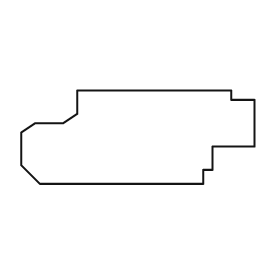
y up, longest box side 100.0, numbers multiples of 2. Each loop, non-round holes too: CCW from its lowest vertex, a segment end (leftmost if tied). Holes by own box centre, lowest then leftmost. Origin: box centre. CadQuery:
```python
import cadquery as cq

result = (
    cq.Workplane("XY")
    .moveTo(-42.0, -20.0)
    .lineTo(28.0, -20.0)
    .lineTo(28.0, -14.0)
    .lineTo(32.0, -14.0)
    .lineTo(32.0, -4.0)
    .lineTo(50.0, -4.0)
    .lineTo(50.0, 16.0)
    .lineTo(40.0, 16.0)
    .lineTo(40.0, 20.0)
    .lineTo(-26.0, 20.0)
    .lineTo(-26.0, 10.0)
    .lineTo(-32.0, 6.0)
    .lineTo(-44.0, 6.0)
    .lineTo(-50.0, 2.0)
    .lineTo(-50.0, -12.0)
    .close()
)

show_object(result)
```